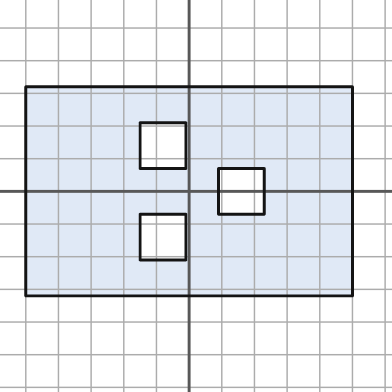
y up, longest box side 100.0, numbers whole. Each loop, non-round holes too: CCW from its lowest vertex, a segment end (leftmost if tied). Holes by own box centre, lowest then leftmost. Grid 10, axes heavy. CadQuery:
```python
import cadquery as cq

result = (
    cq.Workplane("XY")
    .moveTo(-50.0, -32.0)
    .lineTo(50.0, -32.0)
    .lineTo(50.0, 32.0)
    .lineTo(-50.0, 32.0)
    .close()
    .moveTo(-15.0, -21.0)
    .lineTo(-1.0, -21.0)
    .lineTo(-1.0, -7.0)
    .lineTo(-15.0, -7.0)
    .close()
    .moveTo(9.0, -7.0)
    .lineTo(23.0, -7.0)
    .lineTo(23.0, 7.0)
    .lineTo(9.0, 7.0)
    .close()
    .moveTo(-15.0, 7.0)
    .lineTo(-1.0, 7.0)
    .lineTo(-1.0, 21.0)
    .lineTo(-15.0, 21.0)
    .close()
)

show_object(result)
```